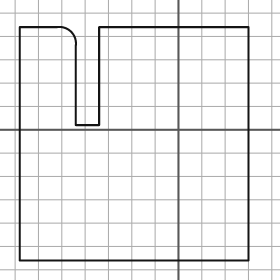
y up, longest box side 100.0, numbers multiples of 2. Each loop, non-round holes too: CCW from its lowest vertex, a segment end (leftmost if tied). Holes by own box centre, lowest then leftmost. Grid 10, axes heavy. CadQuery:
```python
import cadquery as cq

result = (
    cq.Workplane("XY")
    .moveTo(-68.0, -56.0)
    .lineTo(30.0, -56.0)
    .lineTo(30.0, 44.0)
    .lineTo(-34.0, 44.0)
    .lineTo(-34.0, 2.0)
    .lineTo(-44.0, 2.0)
    .lineTo(-44.0, 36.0)
    .threePointArc((-46.0, 42.0), (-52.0, 44.0))
    .lineTo(-68.0, 44.0)
    .close()
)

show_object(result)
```